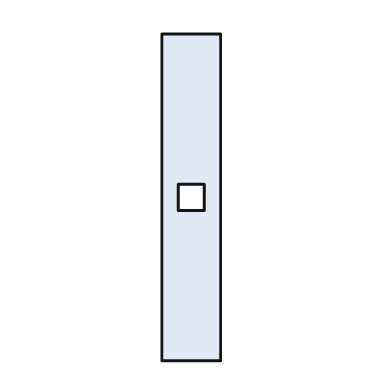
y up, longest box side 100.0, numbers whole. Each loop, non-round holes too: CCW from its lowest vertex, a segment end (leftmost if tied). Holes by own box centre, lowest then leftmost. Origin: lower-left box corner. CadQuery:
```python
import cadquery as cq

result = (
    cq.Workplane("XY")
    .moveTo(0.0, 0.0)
    .lineTo(18.0, 0.0)
    .lineTo(18.0, 100.0)
    .lineTo(0.0, 100.0)
    .close()
    .moveTo(5.0, 46.0)
    .lineTo(13.0, 46.0)
    .lineTo(13.0, 54.0)
    .lineTo(5.0, 54.0)
    .close()
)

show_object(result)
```